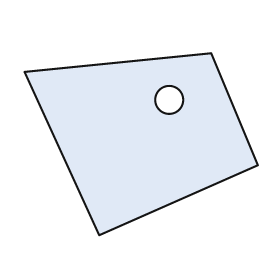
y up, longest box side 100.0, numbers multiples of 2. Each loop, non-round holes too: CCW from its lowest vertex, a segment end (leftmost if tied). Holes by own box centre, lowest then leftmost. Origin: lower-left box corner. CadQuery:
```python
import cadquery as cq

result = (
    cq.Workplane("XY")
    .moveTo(32.0, 0.0)
    .lineTo(100.0, 30.0)
    .lineTo(80.0, 78.0)
    .lineTo(0.0, 70.0)
    .close()
    .moveTo(62.0, 58.0)
    .circle(6.0)
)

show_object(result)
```